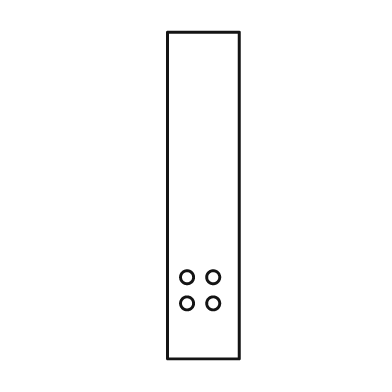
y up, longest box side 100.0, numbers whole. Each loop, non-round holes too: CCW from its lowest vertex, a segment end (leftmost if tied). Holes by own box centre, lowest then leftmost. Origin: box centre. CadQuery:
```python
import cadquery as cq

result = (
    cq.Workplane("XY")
    .moveTo(-11.0, -50.0)
    .lineTo(11.0, -50.0)
    .lineTo(11.0, 50.0)
    .lineTo(-11.0, 50.0)
    .close()
    .moveTo(-5.0, -33.0)
    .circle(2.0)
    .moveTo(3.0, -33.0)
    .circle(2.0)
    .moveTo(-5.0, -25.0)
    .circle(2.0)
    .moveTo(3.0, -25.0)
    .circle(2.0)
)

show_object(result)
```